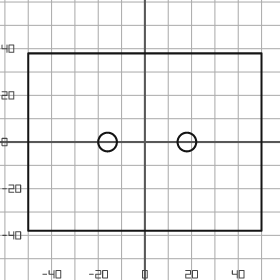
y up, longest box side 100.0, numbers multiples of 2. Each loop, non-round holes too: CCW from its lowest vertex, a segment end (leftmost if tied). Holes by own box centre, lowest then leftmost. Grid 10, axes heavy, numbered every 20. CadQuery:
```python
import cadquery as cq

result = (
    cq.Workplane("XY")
    .moveTo(-50.0, -38.0)
    .lineTo(50.0, -38.0)
    .lineTo(50.0, 38.0)
    .lineTo(-50.0, 38.0)
    .close()
    .moveTo(-16.0, 0.0)
    .circle(4.0)
    .moveTo(18.0, 0.0)
    .circle(4.0)
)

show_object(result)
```